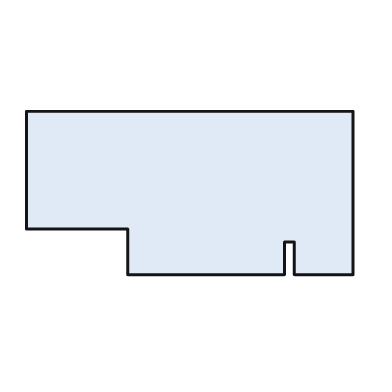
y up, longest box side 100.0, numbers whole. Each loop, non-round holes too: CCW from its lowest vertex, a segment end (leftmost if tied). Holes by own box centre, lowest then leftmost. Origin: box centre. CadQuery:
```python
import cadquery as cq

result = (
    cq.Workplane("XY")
    .moveTo(-19.0, -25.0)
    .lineTo(29.0, -25.0)
    .lineTo(29.0, -15.0)
    .lineTo(32.0, -15.0)
    .lineTo(32.0, -25.0)
    .lineTo(50.0, -25.0)
    .lineTo(50.0, 25.0)
    .lineTo(-50.0, 25.0)
    .lineTo(-50.0, -11.0)
    .lineTo(-19.0, -11.0)
    .close()
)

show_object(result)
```